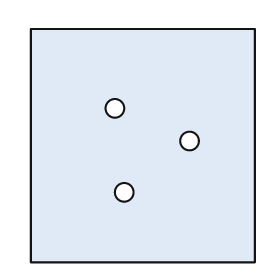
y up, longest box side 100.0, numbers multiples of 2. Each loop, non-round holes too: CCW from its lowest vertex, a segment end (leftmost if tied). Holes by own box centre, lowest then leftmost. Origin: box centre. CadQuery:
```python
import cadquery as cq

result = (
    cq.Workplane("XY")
    .moveTo(-48.0, -50.0)
    .lineTo(48.0, -50.0)
    .lineTo(48.0, 50.0)
    .lineTo(-48.0, 50.0)
    .close()
    .moveTo(-8.0, -20.0)
    .circle(4.0)
    .moveTo(20.0, 2.0)
    .circle(4.0)
    .moveTo(-12.0, 16.0)
    .circle(4.0)
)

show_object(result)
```